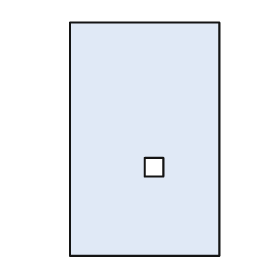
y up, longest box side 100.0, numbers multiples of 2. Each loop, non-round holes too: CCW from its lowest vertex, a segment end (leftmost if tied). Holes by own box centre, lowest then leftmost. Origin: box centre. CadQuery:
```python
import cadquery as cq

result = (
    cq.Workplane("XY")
    .moveTo(-32.0, -50.0)
    .lineTo(32.0, -50.0)
    .lineTo(32.0, 50.0)
    .lineTo(-32.0, 50.0)
    .close()
    .moveTo(0.0, -16.0)
    .lineTo(8.0, -16.0)
    .lineTo(8.0, -8.0)
    .lineTo(0.0, -8.0)
    .close()
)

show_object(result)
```